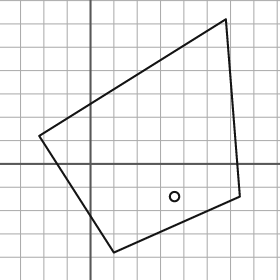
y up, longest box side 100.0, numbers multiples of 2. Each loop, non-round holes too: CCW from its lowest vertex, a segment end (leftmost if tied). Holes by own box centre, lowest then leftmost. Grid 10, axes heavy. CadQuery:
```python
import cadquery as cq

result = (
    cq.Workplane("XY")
    .moveTo(10.0, -38.0)
    .lineTo(64.0, -14.0)
    .lineTo(58.0, 62.0)
    .lineTo(-22.0, 12.0)
    .close()
    .moveTo(36.0, -14.0)
    .circle(2.0)
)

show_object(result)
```